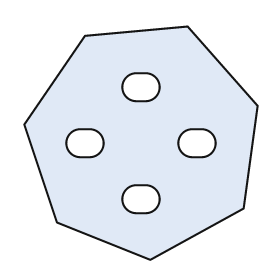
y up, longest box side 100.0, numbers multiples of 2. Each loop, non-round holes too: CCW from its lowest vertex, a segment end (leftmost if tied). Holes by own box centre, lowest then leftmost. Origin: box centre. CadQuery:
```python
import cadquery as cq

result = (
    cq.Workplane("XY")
    .moveTo(4.0, -50.0)
    .lineTo(44.0, -28.0)
    .lineTo(50.0, 16.0)
    .lineTo(20.0, 50.0)
    .lineTo(-24.0, 46.0)
    .lineTo(-50.0, 8.0)
    .lineTo(-36.0, -34.0)
    .close()
    .moveTo(-2.0, -30.0)
    .lineTo(2.0, -30.0)
    .threePointArc((8.0, -24.0), (2.0, -18.0))
    .lineTo(-2.0, -18.0)
    .threePointArc((-8.0, -24.0), (-2.0, -30.0))
    .close()
    .moveTo(-26.0, -6.0)
    .lineTo(-22.0, -6.0)
    .threePointArc((-16.0, 0.0), (-22.0, 6.0))
    .lineTo(-26.0, 6.0)
    .threePointArc((-32.0, 0.0), (-26.0, -6.0))
    .close()
    .moveTo(22.0, -6.0)
    .lineTo(26.0, -6.0)
    .threePointArc((32.0, 0.0), (26.0, 6.0))
    .lineTo(22.0, 6.0)
    .threePointArc((16.0, 0.0), (22.0, -6.0))
    .close()
    .moveTo(-2.0, 18.0)
    .lineTo(2.0, 18.0)
    .threePointArc((8.0, 24.0), (2.0, 30.0))
    .lineTo(-2.0, 30.0)
    .threePointArc((-8.0, 24.0), (-2.0, 18.0))
    .close()
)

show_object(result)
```